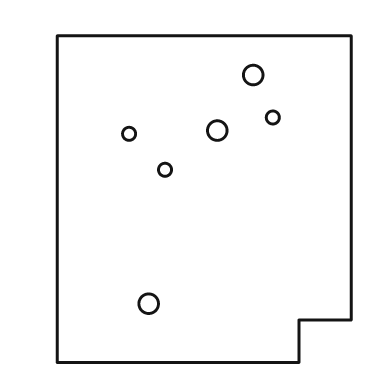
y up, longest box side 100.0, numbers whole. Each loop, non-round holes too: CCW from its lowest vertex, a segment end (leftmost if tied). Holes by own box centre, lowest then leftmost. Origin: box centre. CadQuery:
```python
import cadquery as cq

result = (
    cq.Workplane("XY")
    .moveTo(-45.0, -50.0)
    .lineTo(29.0, -50.0)
    .lineTo(29.0, -37.0)
    .lineTo(45.0, -37.0)
    .lineTo(45.0, 50.0)
    .lineTo(-45.0, 50.0)
    .close()
    .moveTo(-17.0, -32.0)
    .circle(3.0)
    .moveTo(-12.0, 9.0)
    .circle(2.0)
    .moveTo(-23.0, 20.0)
    .circle(2.0)
    .moveTo(4.0, 21.0)
    .circle(3.0)
    .moveTo(21.0, 25.0)
    .circle(2.0)
    .moveTo(15.0, 38.0)
    .circle(3.0)
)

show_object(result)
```